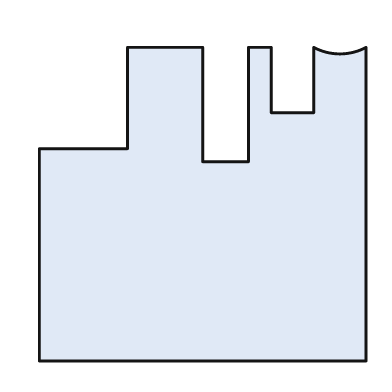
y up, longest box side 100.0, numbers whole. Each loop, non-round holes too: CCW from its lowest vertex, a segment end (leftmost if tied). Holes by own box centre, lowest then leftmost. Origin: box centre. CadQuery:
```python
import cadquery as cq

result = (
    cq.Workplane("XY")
    .moveTo(-50.0, -48.0)
    .lineTo(50.0, -48.0)
    .lineTo(50.0, 48.0)
    .threePointArc((42.0, 46.0), (34.0, 48.0))
    .lineTo(34.0, 28.0)
    .lineTo(21.0, 28.0)
    .lineTo(21.0, 48.0)
    .lineTo(14.0, 48.0)
    .lineTo(14.0, 13.0)
    .lineTo(0.0, 13.0)
    .lineTo(0.0, 48.0)
    .lineTo(-23.0, 48.0)
    .lineTo(-23.0, 17.0)
    .lineTo(-50.0, 17.0)
    .close()
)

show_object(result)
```